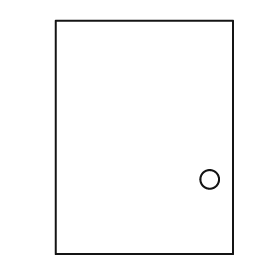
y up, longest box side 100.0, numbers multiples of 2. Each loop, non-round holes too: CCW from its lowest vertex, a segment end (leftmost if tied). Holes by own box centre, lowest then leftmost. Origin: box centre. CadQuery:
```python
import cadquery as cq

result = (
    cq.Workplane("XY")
    .moveTo(-38.0, -50.0)
    .lineTo(38.0, -50.0)
    .lineTo(38.0, 50.0)
    .lineTo(-38.0, 50.0)
    .close()
    .moveTo(28.0, -18.0)
    .circle(4.0)
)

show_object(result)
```